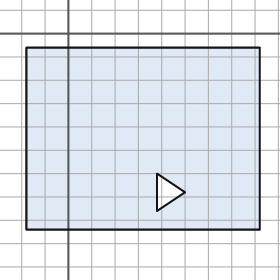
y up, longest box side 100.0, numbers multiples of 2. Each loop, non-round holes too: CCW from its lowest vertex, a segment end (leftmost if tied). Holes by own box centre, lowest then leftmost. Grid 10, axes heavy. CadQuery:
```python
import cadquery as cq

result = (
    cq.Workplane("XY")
    .moveTo(-18.0, -84.0)
    .lineTo(82.0, -84.0)
    .lineTo(82.0, -6.0)
    .lineTo(-18.0, -6.0)
    .close()
    .moveTo(38.0, -76.0)
    .lineTo(50.0, -68.0)
    .lineTo(38.0, -60.0)
    .close()
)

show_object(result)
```